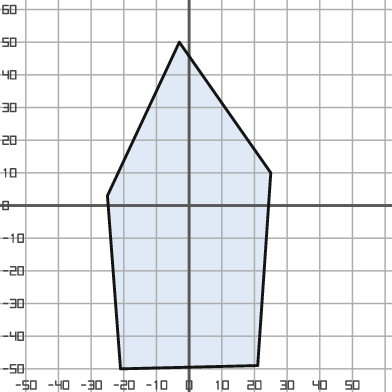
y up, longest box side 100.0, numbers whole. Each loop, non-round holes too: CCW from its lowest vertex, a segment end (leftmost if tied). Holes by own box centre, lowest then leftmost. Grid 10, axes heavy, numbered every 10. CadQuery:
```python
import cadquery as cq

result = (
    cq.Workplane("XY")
    .moveTo(-21.0, -50.0)
    .lineTo(21.0, -49.0)
    .lineTo(25.0, 10.0)
    .lineTo(-3.0, 50.0)
    .lineTo(-25.0, 3.0)
    .close()
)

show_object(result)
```